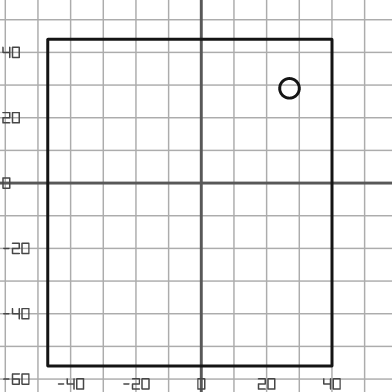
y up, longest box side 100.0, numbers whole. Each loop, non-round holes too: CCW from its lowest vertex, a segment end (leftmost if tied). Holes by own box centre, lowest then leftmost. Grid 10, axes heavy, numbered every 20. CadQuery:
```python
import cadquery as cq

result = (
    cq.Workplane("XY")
    .moveTo(-47.0, -56.0)
    .lineTo(40.0, -56.0)
    .lineTo(40.0, 44.0)
    .lineTo(-47.0, 44.0)
    .close()
    .moveTo(27.0, 29.0)
    .circle(3.0)
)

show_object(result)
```